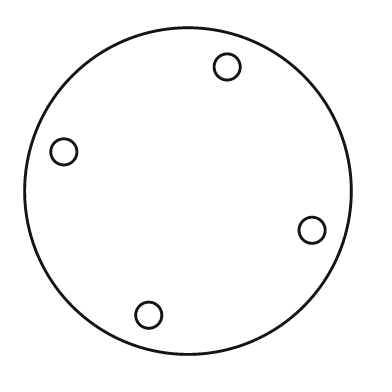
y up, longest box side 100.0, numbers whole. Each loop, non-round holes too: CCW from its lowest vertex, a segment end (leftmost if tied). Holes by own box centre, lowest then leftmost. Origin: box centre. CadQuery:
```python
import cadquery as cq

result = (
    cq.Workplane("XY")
    .moveTo(0.0, 0.0)
    .circle(50.0)
    .moveTo(-12.0, -38.0)
    .circle(4.0)
    .moveTo(38.0, -12.0)
    .circle(4.0)
    .moveTo(-38.0, 12.0)
    .circle(4.0)
    .moveTo(12.0, 38.0)
    .circle(4.0)
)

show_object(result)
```